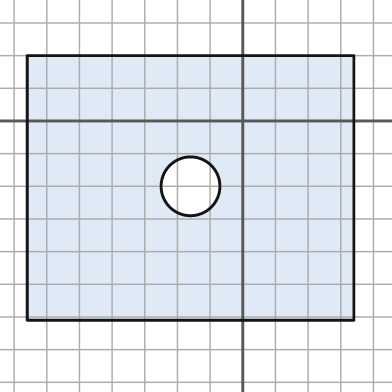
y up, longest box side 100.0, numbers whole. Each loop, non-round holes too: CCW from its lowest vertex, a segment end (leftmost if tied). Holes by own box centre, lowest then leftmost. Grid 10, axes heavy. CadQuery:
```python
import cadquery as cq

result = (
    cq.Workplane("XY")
    .moveTo(-66.0, -61.0)
    .lineTo(34.0, -61.0)
    .lineTo(34.0, 20.0)
    .lineTo(-66.0, 20.0)
    .close()
    .moveTo(-16.0, -20.0)
    .circle(9.0)
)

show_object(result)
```